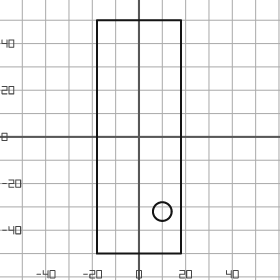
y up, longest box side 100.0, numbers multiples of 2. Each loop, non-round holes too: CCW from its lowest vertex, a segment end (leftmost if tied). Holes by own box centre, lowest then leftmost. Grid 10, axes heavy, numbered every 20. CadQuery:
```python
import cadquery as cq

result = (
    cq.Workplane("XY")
    .moveTo(-18.0, -50.0)
    .lineTo(18.0, -50.0)
    .lineTo(18.0, 50.0)
    .lineTo(-18.0, 50.0)
    .close()
    .moveTo(10.0, -32.0)
    .circle(4.0)
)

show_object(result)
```